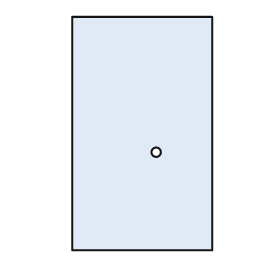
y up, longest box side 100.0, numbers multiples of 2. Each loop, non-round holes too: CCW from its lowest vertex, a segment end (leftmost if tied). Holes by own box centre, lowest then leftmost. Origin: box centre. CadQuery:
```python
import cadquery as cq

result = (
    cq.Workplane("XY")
    .moveTo(-30.0, -50.0)
    .lineTo(30.0, -50.0)
    .lineTo(30.0, 50.0)
    .lineTo(-30.0, 50.0)
    .close()
    .moveTo(6.0, -8.0)
    .circle(2.0)
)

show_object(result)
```